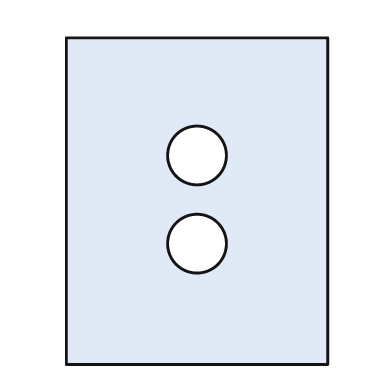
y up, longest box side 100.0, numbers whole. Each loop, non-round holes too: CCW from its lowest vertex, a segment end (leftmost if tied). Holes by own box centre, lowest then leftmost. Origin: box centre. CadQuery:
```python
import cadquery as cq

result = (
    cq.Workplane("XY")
    .moveTo(-40.0, -50.0)
    .lineTo(40.0, -50.0)
    .lineTo(40.0, 50.0)
    .lineTo(-40.0, 50.0)
    .close()
    .moveTo(0.0, -13.0)
    .circle(9.0)
    .moveTo(0.0, 14.0)
    .circle(9.0)
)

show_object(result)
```